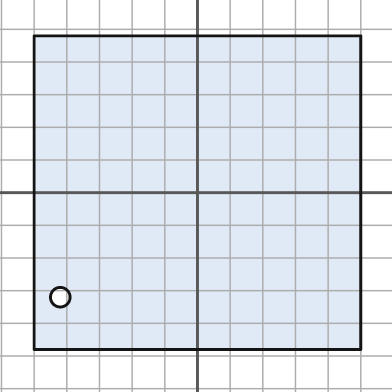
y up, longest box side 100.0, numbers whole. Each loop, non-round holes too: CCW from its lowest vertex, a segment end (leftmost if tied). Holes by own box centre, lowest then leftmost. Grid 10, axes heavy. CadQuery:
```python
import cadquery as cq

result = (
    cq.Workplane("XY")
    .moveTo(-50.0, -48.0)
    .lineTo(50.0, -48.0)
    .lineTo(50.0, 48.0)
    .lineTo(-50.0, 48.0)
    .close()
    .moveTo(-42.0, -32.0)
    .circle(3.0)
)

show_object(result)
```